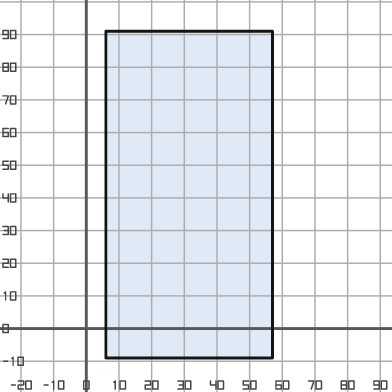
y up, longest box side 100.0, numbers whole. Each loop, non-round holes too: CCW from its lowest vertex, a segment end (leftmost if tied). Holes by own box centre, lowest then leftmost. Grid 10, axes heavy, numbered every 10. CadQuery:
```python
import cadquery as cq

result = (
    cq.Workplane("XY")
    .moveTo(6.0, -9.0)
    .lineTo(57.0, -9.0)
    .lineTo(57.0, 91.0)
    .lineTo(6.0, 91.0)
    .close()
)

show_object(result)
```